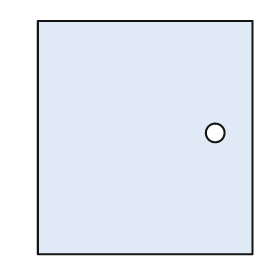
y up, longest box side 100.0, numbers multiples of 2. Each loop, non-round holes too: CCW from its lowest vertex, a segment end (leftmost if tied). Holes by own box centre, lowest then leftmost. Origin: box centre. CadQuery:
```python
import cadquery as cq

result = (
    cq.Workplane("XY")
    .moveTo(-46.0, -50.0)
    .lineTo(46.0, -50.0)
    .lineTo(46.0, 50.0)
    .lineTo(-46.0, 50.0)
    .close()
    .moveTo(30.0, 2.0)
    .circle(4.0)
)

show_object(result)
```